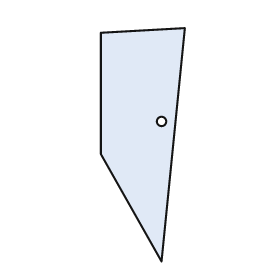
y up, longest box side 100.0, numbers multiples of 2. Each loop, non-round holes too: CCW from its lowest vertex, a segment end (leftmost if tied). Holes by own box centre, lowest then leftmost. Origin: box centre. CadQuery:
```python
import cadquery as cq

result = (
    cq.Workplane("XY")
    .moveTo(8.0, -50.0)
    .lineTo(18.0, 50.0)
    .lineTo(-18.0, 48.0)
    .lineTo(-18.0, -4.0)
    .close()
    .moveTo(8.0, 10.0)
    .circle(2.0)
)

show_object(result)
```